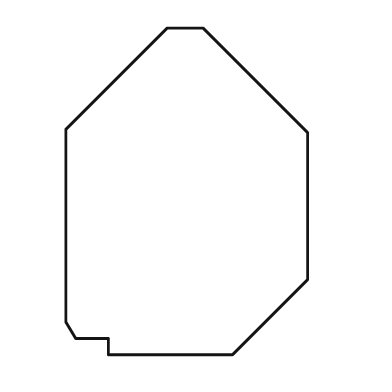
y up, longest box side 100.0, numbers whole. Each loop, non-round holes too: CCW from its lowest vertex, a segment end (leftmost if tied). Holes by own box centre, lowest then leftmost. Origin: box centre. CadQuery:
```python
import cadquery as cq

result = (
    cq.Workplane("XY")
    .moveTo(-24.0, -50.0)
    .lineTo(14.0, -50.0)
    .lineTo(37.0, -27.0)
    .lineTo(37.0, 18.0)
    .lineTo(5.0, 50.0)
    .lineTo(-6.0, 50.0)
    .lineTo(-37.0, 19.0)
    .lineTo(-37.0, -40.0)
    .lineTo(-34.0, -45.0)
    .lineTo(-24.0, -45.0)
    .close()
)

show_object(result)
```